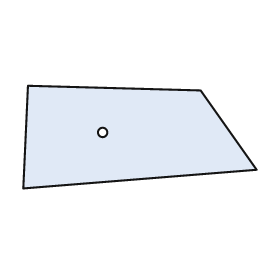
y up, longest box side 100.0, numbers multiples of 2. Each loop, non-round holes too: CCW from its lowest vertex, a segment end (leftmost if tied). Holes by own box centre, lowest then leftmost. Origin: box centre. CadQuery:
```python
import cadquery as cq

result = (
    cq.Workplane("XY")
    .moveTo(-50.0, -22.0)
    .lineTo(50.0, -14.0)
    .lineTo(26.0, 20.0)
    .lineTo(-48.0, 22.0)
    .close()
    .moveTo(-16.0, 2.0)
    .circle(2.0)
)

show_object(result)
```